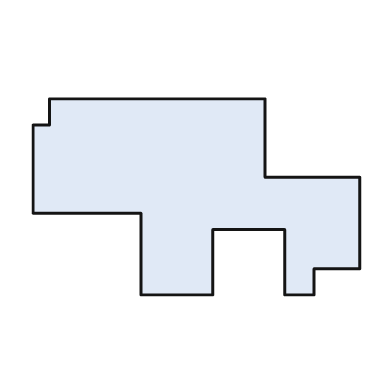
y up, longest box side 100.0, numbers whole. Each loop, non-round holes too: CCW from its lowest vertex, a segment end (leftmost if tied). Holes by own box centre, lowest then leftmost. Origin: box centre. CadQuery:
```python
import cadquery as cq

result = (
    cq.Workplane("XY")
    .moveTo(-17.0, -30.0)
    .lineTo(5.0, -30.0)
    .lineTo(5.0, -10.0)
    .lineTo(27.0, -10.0)
    .lineTo(27.0, -30.0)
    .lineTo(36.0, -30.0)
    .lineTo(36.0, -22.0)
    .lineTo(50.0, -22.0)
    .lineTo(50.0, 6.0)
    .lineTo(21.0, 6.0)
    .lineTo(21.0, 30.0)
    .lineTo(-45.0, 30.0)
    .lineTo(-45.0, 22.0)
    .lineTo(-50.0, 22.0)
    .lineTo(-50.0, -5.0)
    .lineTo(-17.0, -5.0)
    .close()
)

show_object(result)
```